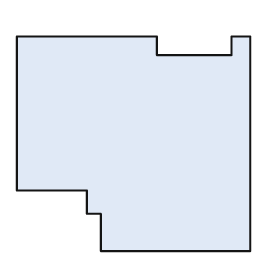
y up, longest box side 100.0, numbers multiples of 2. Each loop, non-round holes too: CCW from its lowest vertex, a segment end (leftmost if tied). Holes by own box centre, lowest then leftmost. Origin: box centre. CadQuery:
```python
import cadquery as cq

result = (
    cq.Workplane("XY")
    .moveTo(-14.0, -46.0)
    .lineTo(50.0, -46.0)
    .lineTo(50.0, 46.0)
    .lineTo(42.0, 46.0)
    .lineTo(42.0, 38.0)
    .lineTo(10.0, 38.0)
    .lineTo(10.0, 46.0)
    .lineTo(-50.0, 46.0)
    .lineTo(-50.0, -20.0)
    .lineTo(-20.0, -20.0)
    .lineTo(-20.0, -30.0)
    .lineTo(-14.0, -30.0)
    .close()
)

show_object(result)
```